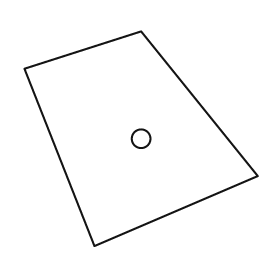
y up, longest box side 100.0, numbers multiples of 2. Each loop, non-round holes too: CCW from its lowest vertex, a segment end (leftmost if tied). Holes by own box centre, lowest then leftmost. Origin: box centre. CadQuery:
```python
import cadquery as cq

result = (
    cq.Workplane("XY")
    .moveTo(-20.0, -46.0)
    .lineTo(50.0, -16.0)
    .lineTo(0.0, 46.0)
    .lineTo(-50.0, 30.0)
    .close()
    .moveTo(0.0, 0.0)
    .circle(4.0)
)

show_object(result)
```